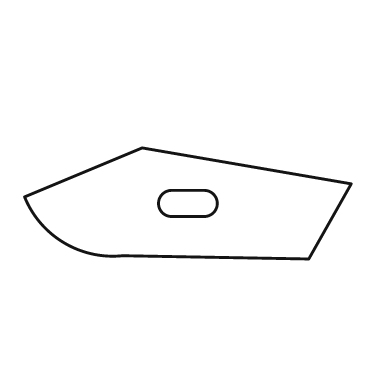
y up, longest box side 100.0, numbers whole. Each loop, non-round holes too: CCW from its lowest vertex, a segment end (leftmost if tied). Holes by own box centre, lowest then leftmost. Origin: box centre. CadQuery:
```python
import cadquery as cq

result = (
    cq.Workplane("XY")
    .moveTo(37.0, -17.0)
    .lineTo(50.0, 6.0)
    .lineTo(-14.0, 17.0)
    .lineTo(-50.0, 2.0)
    .threePointArc((-38.0, -12.0), (-20.0, -16.0))
    .close()
    .moveTo(-5.0, -4.0)
    .lineTo(5.0, -4.0)
    .threePointArc((9.0, 0.0), (5.0, 4.0))
    .lineTo(-5.0, 4.0)
    .threePointArc((-9.0, 0.0), (-5.0, -4.0))
    .close()
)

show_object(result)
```